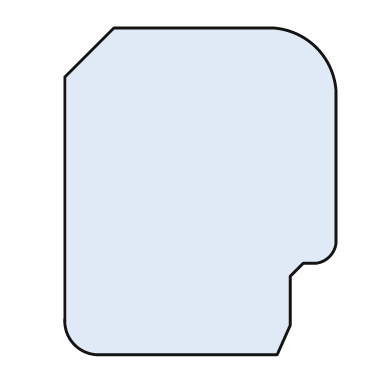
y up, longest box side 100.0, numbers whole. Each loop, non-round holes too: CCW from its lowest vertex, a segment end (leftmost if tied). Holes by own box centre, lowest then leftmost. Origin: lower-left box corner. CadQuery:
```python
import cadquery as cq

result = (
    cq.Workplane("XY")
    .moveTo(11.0, 0.0)
    .lineTo(65.0, 0.0)
    .lineTo(69.0, 9.0)
    .lineTo(69.0, 24.0)
    .lineTo(73.0, 28.0)
    .lineTo(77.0, 28.0)
    .threePointArc((81.0, 30.0), (83.0, 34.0))
    .lineTo(83.0, 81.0)
    .threePointArc((77.0, 94.0), (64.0, 100.0))
    .lineTo(15.0, 100.0)
    .lineTo(0.0, 85.0)
    .lineTo(0.0, 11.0)
    .threePointArc((3.0, 3.0), (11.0, 0.0))
    .close()
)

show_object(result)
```